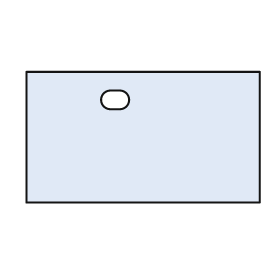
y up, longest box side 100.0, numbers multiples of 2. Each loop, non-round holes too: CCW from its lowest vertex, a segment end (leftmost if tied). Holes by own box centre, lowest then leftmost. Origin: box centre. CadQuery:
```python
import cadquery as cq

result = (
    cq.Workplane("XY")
    .moveTo(-50.0, -28.0)
    .lineTo(50.0, -28.0)
    .lineTo(50.0, 28.0)
    .lineTo(-50.0, 28.0)
    .close()
    .moveTo(-14.0, 12.0)
    .lineTo(-10.0, 12.0)
    .threePointArc((-6.0, 16.0), (-10.0, 20.0))
    .lineTo(-14.0, 20.0)
    .threePointArc((-18.0, 16.0), (-14.0, 12.0))
    .close()
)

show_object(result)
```